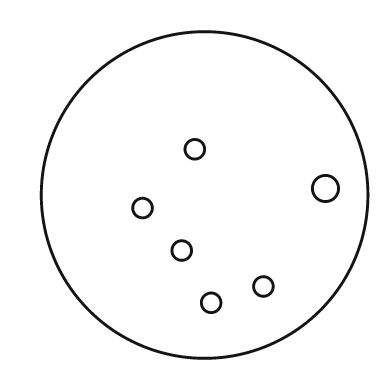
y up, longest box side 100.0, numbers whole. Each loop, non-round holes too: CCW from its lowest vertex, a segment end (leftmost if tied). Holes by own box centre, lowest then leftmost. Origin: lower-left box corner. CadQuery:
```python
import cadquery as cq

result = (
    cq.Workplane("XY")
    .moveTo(50.0, 50.0)
    .circle(50.0)
    .moveTo(52.0, 17.0)
    .circle(3.0)
    .moveTo(68.0, 22.0)
    .circle(3.0)
    .moveTo(43.0, 33.0)
    .circle(3.0)
    .moveTo(31.0, 46.0)
    .circle(3.0)
    .moveTo(87.0, 52.0)
    .circle(4.0)
    .moveTo(47.0, 64.0)
    .circle(3.0)
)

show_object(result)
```